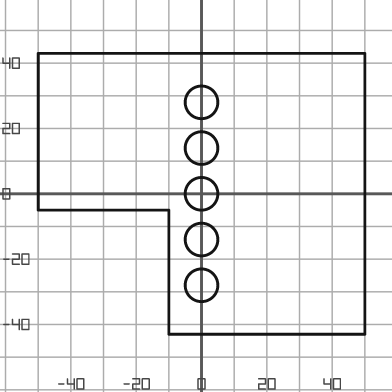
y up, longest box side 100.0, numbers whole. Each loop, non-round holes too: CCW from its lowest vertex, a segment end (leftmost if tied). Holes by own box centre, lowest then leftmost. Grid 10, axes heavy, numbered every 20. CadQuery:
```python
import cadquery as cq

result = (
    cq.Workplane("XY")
    .moveTo(-10.0, -43.0)
    .lineTo(50.0, -43.0)
    .lineTo(50.0, 43.0)
    .lineTo(-50.0, 43.0)
    .lineTo(-50.0, -5.0)
    .lineTo(-10.0, -5.0)
    .close()
    .moveTo(0.0, -28.0)
    .circle(5.0)
    .moveTo(0.0, -14.0)
    .circle(5.0)
    .moveTo(0.0, 0.0)
    .circle(5.0)
    .moveTo(0.0, 14.0)
    .circle(5.0)
    .moveTo(0.0, 28.0)
    .circle(5.0)
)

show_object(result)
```